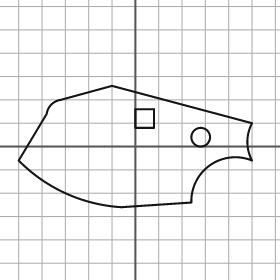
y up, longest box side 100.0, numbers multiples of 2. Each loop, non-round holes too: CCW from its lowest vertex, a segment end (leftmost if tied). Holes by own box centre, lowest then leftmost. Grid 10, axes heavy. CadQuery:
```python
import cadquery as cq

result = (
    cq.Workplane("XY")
    .moveTo(-6.0, -26.0)
    .lineTo(24.0, -24.0)
    .threePointArc((32.0, -8.0), (50.0, -6.0))
    .threePointArc((48.0, 2.0), (50.0, 10.0))
    .lineTo(-10.0, 26.0)
    .lineTo(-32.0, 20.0)
    .threePointArc((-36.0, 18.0), (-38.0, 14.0))
    .lineTo(-50.0, -6.0)
    .threePointArc((-30.0, -20.0), (-6.0, -26.0))
    .close()
    .moveTo(28.0, 4.0)
    .circle(4.0)
    .moveTo(0.0, 8.0)
    .lineTo(8.0, 8.0)
    .lineTo(8.0, 16.0)
    .lineTo(0.0, 16.0)
    .close()
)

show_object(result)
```